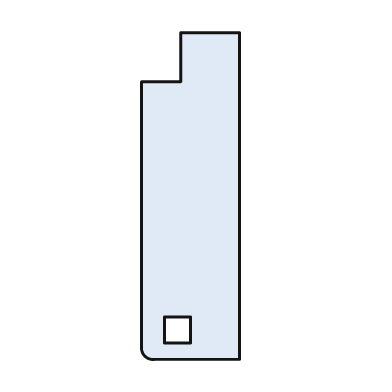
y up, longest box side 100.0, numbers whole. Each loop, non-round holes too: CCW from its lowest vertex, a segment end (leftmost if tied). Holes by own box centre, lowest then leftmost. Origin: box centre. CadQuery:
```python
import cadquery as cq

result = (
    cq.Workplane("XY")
    .moveTo(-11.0, -50.0)
    .lineTo(15.0, -50.0)
    .lineTo(15.0, 50.0)
    .lineTo(-3.0, 50.0)
    .lineTo(-3.0, 35.0)
    .lineTo(-15.0, 35.0)
    .lineTo(-15.0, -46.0)
    .threePointArc((-14.0, -49.0), (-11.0, -50.0))
    .close()
    .moveTo(-8.0, -45.0)
    .lineTo(0.0, -45.0)
    .lineTo(0.0, -37.0)
    .lineTo(-8.0, -37.0)
    .close()
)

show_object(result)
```